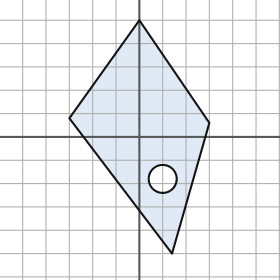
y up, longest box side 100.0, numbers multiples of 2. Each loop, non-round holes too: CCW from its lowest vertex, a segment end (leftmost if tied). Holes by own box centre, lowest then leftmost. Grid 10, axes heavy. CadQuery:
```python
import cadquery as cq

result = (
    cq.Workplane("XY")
    .moveTo(14.0, -50.0)
    .lineTo(30.0, 6.0)
    .lineTo(0.0, 50.0)
    .lineTo(-30.0, 8.0)
    .close()
    .moveTo(10.0, -18.0)
    .circle(6.0)
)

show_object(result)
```